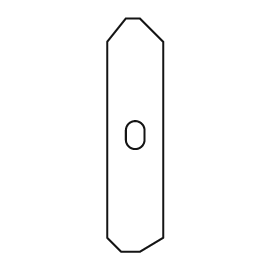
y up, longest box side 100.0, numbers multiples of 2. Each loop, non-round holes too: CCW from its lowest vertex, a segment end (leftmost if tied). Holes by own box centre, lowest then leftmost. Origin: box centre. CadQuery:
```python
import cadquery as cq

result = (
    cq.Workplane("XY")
    .moveTo(-6.0, -50.0)
    .lineTo(2.0, -50.0)
    .lineTo(12.0, -44.0)
    .lineTo(12.0, 40.0)
    .lineTo(2.0, 50.0)
    .lineTo(-4.0, 50.0)
    .lineTo(-12.0, 40.0)
    .lineTo(-12.0, -44.0)
    .close()
    .moveTo(-4.0, -2.0)
    .threePointArc((0.0, -6.0), (4.0, -2.0))
    .lineTo(4.0, 2.0)
    .threePointArc((0.0, 6.0), (-4.0, 2.0))
    .close()
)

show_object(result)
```